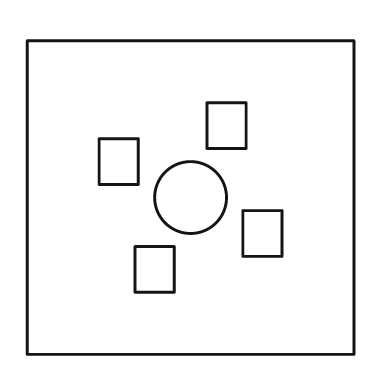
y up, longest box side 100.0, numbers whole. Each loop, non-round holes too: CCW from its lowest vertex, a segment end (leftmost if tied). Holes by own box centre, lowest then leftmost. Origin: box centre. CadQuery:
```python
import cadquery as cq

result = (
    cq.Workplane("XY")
    .moveTo(-50.0, -48.0)
    .lineTo(50.0, -48.0)
    .lineTo(50.0, 48.0)
    .lineTo(-50.0, 48.0)
    .close()
    .moveTo(-17.0, -29.0)
    .lineTo(-5.0, -29.0)
    .lineTo(-5.0, -15.0)
    .lineTo(-17.0, -15.0)
    .close()
    .moveTo(16.0, -18.0)
    .lineTo(28.0, -18.0)
    .lineTo(28.0, -4.0)
    .lineTo(16.0, -4.0)
    .close()
    .moveTo(0.0, 0.0)
    .circle(11.0)
    .moveTo(-28.0, 4.0)
    .lineTo(-16.0, 4.0)
    .lineTo(-16.0, 18.0)
    .lineTo(-28.0, 18.0)
    .close()
    .moveTo(5.0, 15.0)
    .lineTo(17.0, 15.0)
    .lineTo(17.0, 29.0)
    .lineTo(5.0, 29.0)
    .close()
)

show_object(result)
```